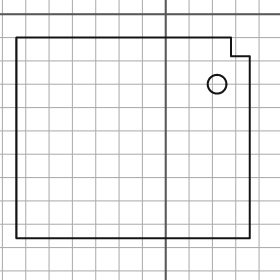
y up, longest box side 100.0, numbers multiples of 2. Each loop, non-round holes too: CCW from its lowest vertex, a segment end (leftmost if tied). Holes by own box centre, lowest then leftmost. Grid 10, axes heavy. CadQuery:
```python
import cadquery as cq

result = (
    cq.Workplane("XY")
    .moveTo(-64.0, -96.0)
    .lineTo(36.0, -96.0)
    .lineTo(36.0, -18.0)
    .lineTo(28.0, -18.0)
    .lineTo(28.0, -10.0)
    .lineTo(-64.0, -10.0)
    .close()
    .moveTo(22.0, -30.0)
    .circle(4.0)
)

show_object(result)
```